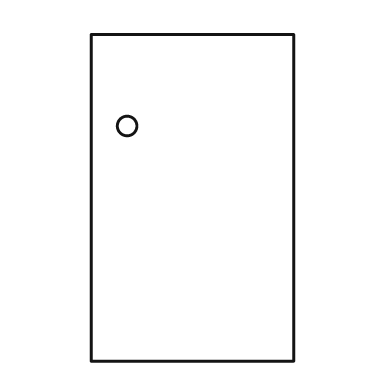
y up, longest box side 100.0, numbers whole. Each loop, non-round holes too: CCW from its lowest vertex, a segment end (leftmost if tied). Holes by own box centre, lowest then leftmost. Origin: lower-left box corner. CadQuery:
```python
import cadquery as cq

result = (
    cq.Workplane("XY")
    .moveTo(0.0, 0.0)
    .lineTo(62.0, 0.0)
    .lineTo(62.0, 100.0)
    .lineTo(0.0, 100.0)
    .close()
    .moveTo(11.0, 72.0)
    .circle(3.0)
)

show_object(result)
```